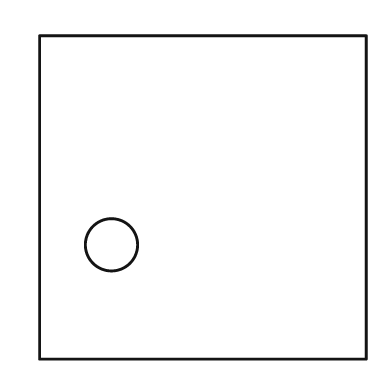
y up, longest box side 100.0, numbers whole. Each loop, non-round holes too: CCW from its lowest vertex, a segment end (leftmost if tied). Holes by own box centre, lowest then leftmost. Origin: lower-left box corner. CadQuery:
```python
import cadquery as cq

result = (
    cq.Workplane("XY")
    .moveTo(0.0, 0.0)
    .lineTo(100.0, 0.0)
    .lineTo(100.0, 99.0)
    .lineTo(0.0, 99.0)
    .close()
    .moveTo(22.0, 35.0)
    .circle(8.0)
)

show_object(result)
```